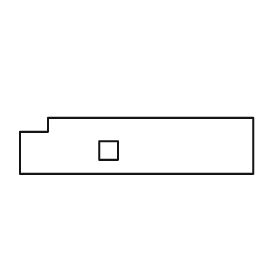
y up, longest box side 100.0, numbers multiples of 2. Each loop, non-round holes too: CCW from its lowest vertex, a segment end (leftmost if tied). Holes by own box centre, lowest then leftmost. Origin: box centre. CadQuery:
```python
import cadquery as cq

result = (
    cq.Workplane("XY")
    .moveTo(-50.0, -12.0)
    .lineTo(50.0, -12.0)
    .lineTo(50.0, 12.0)
    .lineTo(-38.0, 12.0)
    .lineTo(-38.0, 6.0)
    .lineTo(-50.0, 6.0)
    .close()
    .moveTo(-16.0, -6.0)
    .lineTo(-8.0, -6.0)
    .lineTo(-8.0, 2.0)
    .lineTo(-16.0, 2.0)
    .close()
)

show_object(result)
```